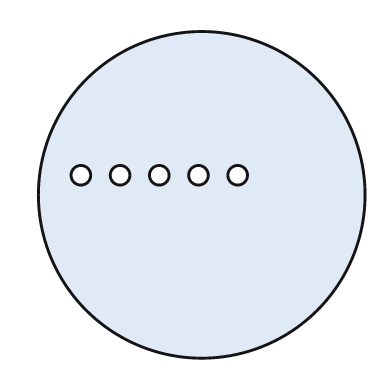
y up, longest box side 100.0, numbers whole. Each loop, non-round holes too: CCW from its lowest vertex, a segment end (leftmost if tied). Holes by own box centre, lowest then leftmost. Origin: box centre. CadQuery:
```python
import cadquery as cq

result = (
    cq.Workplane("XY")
    .moveTo(0.0, 0.0)
    .circle(50.0)
    .moveTo(-37.0, 6.0)
    .circle(3.0)
    .moveTo(-25.0, 6.0)
    .circle(3.0)
    .moveTo(-13.0, 6.0)
    .circle(3.0)
    .moveTo(-1.0, 6.0)
    .circle(3.0)
    .moveTo(11.0, 6.0)
    .circle(3.0)
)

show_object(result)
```